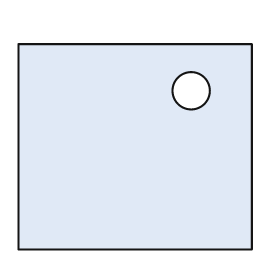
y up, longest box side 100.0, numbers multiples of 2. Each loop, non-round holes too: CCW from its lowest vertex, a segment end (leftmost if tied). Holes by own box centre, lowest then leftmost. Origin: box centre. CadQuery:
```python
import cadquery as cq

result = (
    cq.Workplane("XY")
    .moveTo(-50.0, -44.0)
    .lineTo(50.0, -44.0)
    .lineTo(50.0, 44.0)
    .lineTo(-50.0, 44.0)
    .close()
    .moveTo(24.0, 24.0)
    .circle(8.0)
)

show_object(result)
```